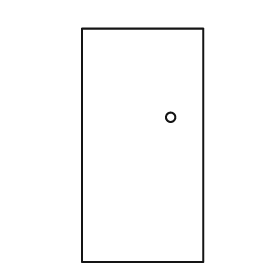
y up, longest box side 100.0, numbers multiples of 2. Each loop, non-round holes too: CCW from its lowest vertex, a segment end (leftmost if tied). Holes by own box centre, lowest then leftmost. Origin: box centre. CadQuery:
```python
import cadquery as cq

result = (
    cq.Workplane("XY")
    .moveTo(-26.0, -50.0)
    .lineTo(26.0, -50.0)
    .lineTo(26.0, 50.0)
    .lineTo(-26.0, 50.0)
    .close()
    .moveTo(12.0, 12.0)
    .circle(2.0)
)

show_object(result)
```